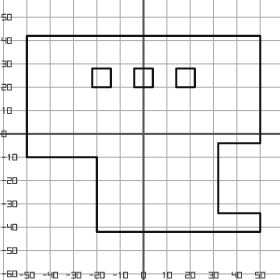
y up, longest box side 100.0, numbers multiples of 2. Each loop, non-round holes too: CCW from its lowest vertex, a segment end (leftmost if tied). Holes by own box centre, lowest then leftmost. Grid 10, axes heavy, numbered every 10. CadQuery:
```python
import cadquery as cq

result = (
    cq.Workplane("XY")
    .moveTo(-20.0, -42.0)
    .lineTo(50.0, -42.0)
    .lineTo(50.0, -34.0)
    .lineTo(32.0, -34.0)
    .lineTo(32.0, -4.0)
    .lineTo(50.0, -4.0)
    .lineTo(50.0, 42.0)
    .lineTo(-50.0, 42.0)
    .lineTo(-50.0, -10.0)
    .lineTo(-20.0, -10.0)
    .close()
    .moveTo(-22.0, 20.0)
    .lineTo(-14.0, 20.0)
    .lineTo(-14.0, 28.0)
    .lineTo(-22.0, 28.0)
    .close()
    .moveTo(-4.0, 20.0)
    .lineTo(4.0, 20.0)
    .lineTo(4.0, 28.0)
    .lineTo(-4.0, 28.0)
    .close()
    .moveTo(14.0, 20.0)
    .lineTo(22.0, 20.0)
    .lineTo(22.0, 28.0)
    .lineTo(14.0, 28.0)
    .close()
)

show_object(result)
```